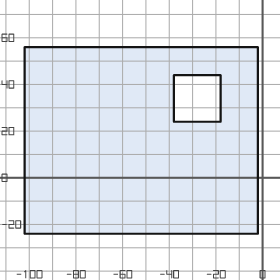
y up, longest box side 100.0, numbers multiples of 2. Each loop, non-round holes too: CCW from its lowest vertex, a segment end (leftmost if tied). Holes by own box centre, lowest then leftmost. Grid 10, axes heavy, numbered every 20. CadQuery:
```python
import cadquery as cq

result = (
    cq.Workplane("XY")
    .moveTo(-102.0, -24.0)
    .lineTo(-2.0, -24.0)
    .lineTo(-2.0, 56.0)
    .lineTo(-102.0, 56.0)
    .close()
    .moveTo(-38.0, 24.0)
    .lineTo(-18.0, 24.0)
    .lineTo(-18.0, 44.0)
    .lineTo(-38.0, 44.0)
    .close()
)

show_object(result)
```